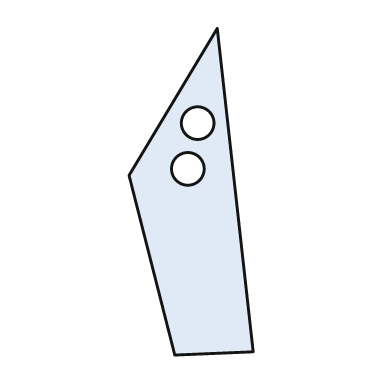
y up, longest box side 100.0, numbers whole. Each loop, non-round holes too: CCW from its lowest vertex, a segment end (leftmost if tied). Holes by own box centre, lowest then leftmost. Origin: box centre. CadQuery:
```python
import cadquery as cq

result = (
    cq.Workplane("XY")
    .moveTo(-5.0, -50.0)
    .lineTo(19.0, -49.0)
    .lineTo(8.0, 50.0)
    .lineTo(-19.0, 5.0)
    .close()
    .moveTo(-1.0, 7.0)
    .circle(5.0)
    .moveTo(2.0, 21.0)
    .circle(5.0)
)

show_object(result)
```